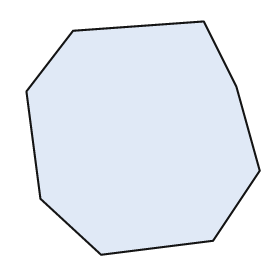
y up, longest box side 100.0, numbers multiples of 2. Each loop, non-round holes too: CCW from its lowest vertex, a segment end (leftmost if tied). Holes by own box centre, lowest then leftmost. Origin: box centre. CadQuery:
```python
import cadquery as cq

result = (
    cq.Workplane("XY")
    .moveTo(-18.0, -50.0)
    .lineTo(30.0, -44.0)
    .lineTo(50.0, -14.0)
    .lineTo(40.0, 22.0)
    .lineTo(26.0, 50.0)
    .lineTo(-30.0, 46.0)
    .lineTo(-50.0, 20.0)
    .lineTo(-44.0, -26.0)
    .close()
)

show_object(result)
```